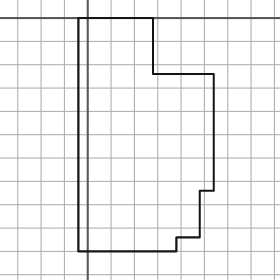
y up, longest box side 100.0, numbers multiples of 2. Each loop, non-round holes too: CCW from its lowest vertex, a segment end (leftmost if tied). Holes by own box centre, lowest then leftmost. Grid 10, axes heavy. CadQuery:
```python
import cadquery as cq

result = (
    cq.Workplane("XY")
    .moveTo(-4.0, -100.0)
    .lineTo(38.0, -100.0)
    .lineTo(38.0, -94.0)
    .lineTo(48.0, -94.0)
    .lineTo(48.0, -74.0)
    .lineTo(54.0, -74.0)
    .lineTo(54.0, -24.0)
    .lineTo(28.0, -24.0)
    .lineTo(28.0, 0.0)
    .lineTo(-4.0, 0.0)
    .close()
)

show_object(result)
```